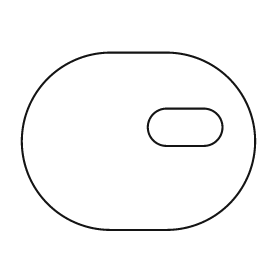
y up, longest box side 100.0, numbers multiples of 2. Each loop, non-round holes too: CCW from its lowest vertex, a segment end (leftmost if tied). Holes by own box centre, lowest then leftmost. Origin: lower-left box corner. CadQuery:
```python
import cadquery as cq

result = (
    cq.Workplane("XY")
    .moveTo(38.0, 0.0)
    .lineTo(62.0, 0.0)
    .threePointArc((100.0, 38.0), (62.0, 76.0))
    .lineTo(38.0, 76.0)
    .threePointArc((0.0, 38.0), (38.0, 0.0))
    .close()
    .moveTo(62.0, 36.0)
    .lineTo(78.0, 36.0)
    .threePointArc((86.0, 44.0), (78.0, 52.0))
    .lineTo(62.0, 52.0)
    .threePointArc((54.0, 44.0), (62.0, 36.0))
    .close()
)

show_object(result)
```